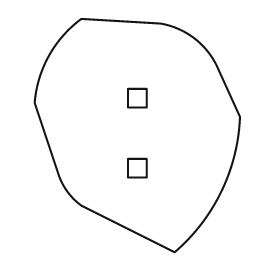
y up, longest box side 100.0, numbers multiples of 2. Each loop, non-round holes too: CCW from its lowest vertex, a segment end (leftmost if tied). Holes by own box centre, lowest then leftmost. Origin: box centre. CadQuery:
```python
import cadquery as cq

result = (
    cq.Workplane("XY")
    .moveTo(16.0, -50.0)
    .threePointArc((36.0, -24.0), (44.0, 8.0))
    .lineTo(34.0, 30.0)
    .threePointArc((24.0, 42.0), (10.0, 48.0))
    .lineTo(-24.0, 50.0)
    .threePointArc((-38.0, 34.0), (-44.0, 14.0))
    .lineTo(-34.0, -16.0)
    .threePointArc((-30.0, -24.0), (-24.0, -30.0))
    .close()
    .moveTo(-4.0, -18.0)
    .lineTo(4.0, -18.0)
    .lineTo(4.0, -10.0)
    .lineTo(-4.0, -10.0)
    .close()
    .moveTo(-4.0, 12.0)
    .lineTo(4.0, 12.0)
    .lineTo(4.0, 20.0)
    .lineTo(-4.0, 20.0)
    .close()
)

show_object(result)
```